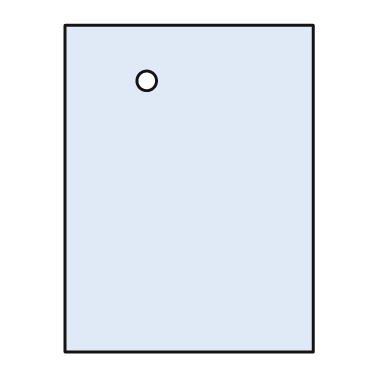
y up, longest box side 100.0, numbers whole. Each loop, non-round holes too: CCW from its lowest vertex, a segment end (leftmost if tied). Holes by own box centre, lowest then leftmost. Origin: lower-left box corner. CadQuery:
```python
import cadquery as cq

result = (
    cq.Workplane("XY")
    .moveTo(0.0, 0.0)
    .lineTo(76.0, 0.0)
    .lineTo(76.0, 100.0)
    .lineTo(0.0, 100.0)
    .close()
    .moveTo(25.0, 83.0)
    .circle(3.0)
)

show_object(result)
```